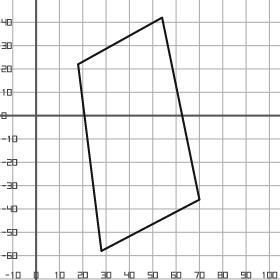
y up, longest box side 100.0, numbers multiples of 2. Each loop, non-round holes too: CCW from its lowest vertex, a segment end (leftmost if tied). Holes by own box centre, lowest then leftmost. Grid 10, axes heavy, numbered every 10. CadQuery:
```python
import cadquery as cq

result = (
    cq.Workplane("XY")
    .moveTo(28.0, -58.0)
    .lineTo(70.0, -36.0)
    .lineTo(54.0, 42.0)
    .lineTo(18.0, 22.0)
    .close()
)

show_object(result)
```